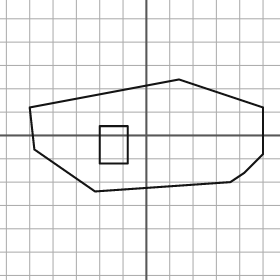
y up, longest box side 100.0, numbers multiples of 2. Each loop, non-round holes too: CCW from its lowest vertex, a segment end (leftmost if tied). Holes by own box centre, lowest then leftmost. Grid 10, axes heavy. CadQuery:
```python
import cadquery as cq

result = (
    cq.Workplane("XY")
    .moveTo(-22.0, -24.0)
    .lineTo(36.0, -20.0)
    .lineTo(42.0, -16.0)
    .lineTo(50.0, -8.0)
    .lineTo(50.0, 12.0)
    .lineTo(14.0, 24.0)
    .lineTo(-50.0, 12.0)
    .lineTo(-48.0, -6.0)
    .close()
    .moveTo(-20.0, -12.0)
    .lineTo(-8.0, -12.0)
    .lineTo(-8.0, 4.0)
    .lineTo(-20.0, 4.0)
    .close()
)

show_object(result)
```